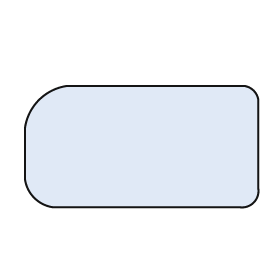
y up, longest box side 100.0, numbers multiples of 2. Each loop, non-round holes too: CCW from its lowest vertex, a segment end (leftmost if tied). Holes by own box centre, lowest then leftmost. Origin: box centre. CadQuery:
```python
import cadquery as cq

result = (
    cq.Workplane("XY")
    .moveTo(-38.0, -26.0)
    .lineTo(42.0, -26.0)
    .threePointArc((48.0, -24.0), (50.0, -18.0))
    .lineTo(50.0, 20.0)
    .threePointArc((48.0, 24.0), (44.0, 26.0))
    .lineTo(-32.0, 26.0)
    .threePointArc((-44.0, 20.0), (-50.0, 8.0))
    .lineTo(-50.0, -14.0)
    .threePointArc((-46.0, -22.0), (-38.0, -26.0))
    .close()
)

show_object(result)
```